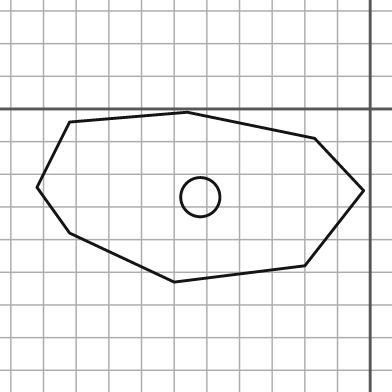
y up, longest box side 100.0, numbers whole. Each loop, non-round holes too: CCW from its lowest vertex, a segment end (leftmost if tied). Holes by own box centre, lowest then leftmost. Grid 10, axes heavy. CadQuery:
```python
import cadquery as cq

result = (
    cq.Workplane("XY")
    .moveTo(-60.0, -53.0)
    .lineTo(-20.0, -48.0)
    .lineTo(-2.0, -25.0)
    .lineTo(-17.0, -9.0)
    .lineTo(-56.0, -1.0)
    .lineTo(-92.0, -4.0)
    .lineTo(-102.0, -24.0)
    .lineTo(-92.0, -38.0)
    .close()
    .moveTo(-52.0, -27.0)
    .circle(6.0)
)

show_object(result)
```